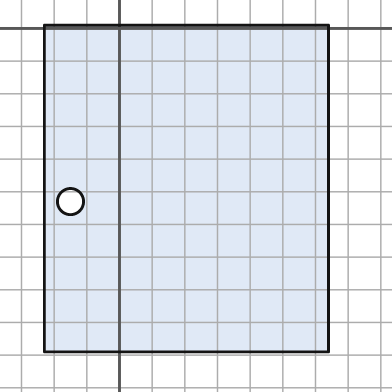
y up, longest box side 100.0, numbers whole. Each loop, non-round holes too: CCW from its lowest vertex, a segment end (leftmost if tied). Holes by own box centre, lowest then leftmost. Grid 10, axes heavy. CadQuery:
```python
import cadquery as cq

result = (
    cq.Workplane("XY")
    .moveTo(-23.0, -99.0)
    .lineTo(64.0, -99.0)
    .lineTo(64.0, 1.0)
    .lineTo(-23.0, 1.0)
    .close()
    .moveTo(-15.0, -53.0)
    .circle(4.0)
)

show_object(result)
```